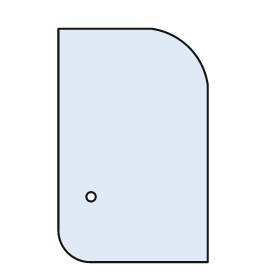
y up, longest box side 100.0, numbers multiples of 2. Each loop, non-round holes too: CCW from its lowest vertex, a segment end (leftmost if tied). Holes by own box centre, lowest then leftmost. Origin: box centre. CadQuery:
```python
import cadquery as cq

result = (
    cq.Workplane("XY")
    .moveTo(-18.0, -50.0)
    .lineTo(32.0, -50.0)
    .lineTo(32.0, 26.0)
    .threePointArc((24.0, 42.0), (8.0, 50.0))
    .lineTo(-32.0, 50.0)
    .lineTo(-32.0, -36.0)
    .threePointArc((-28.0, -46.0), (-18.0, -50.0))
    .close()
    .moveTo(-18.0, -22.0)
    .circle(2.0)
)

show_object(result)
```